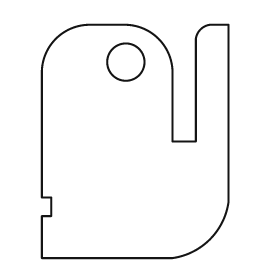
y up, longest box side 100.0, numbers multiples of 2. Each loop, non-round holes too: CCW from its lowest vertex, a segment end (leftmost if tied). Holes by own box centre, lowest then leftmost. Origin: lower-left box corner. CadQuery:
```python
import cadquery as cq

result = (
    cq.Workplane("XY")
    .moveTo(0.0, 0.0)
    .lineTo(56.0, 0.0)
    .threePointArc((72.0, 8.0), (80.0, 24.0))
    .lineTo(80.0, 100.0)
    .lineTo(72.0, 100.0)
    .threePointArc((68.0, 98.0), (66.0, 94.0))
    .lineTo(66.0, 50.0)
    .lineTo(56.0, 50.0)
    .lineTo(56.0, 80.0)
    .threePointArc((50.0, 94.0), (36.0, 100.0))
    .lineTo(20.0, 100.0)
    .threePointArc((6.0, 94.0), (0.0, 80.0))
    .lineTo(0.0, 26.0)
    .lineTo(4.0, 26.0)
    .lineTo(4.0, 18.0)
    .lineTo(0.0, 18.0)
    .close()
    .moveTo(36.0, 84.0)
    .circle(8.0)
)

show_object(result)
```